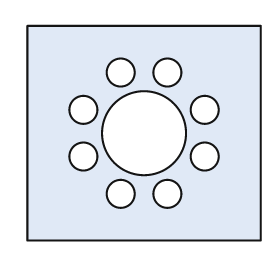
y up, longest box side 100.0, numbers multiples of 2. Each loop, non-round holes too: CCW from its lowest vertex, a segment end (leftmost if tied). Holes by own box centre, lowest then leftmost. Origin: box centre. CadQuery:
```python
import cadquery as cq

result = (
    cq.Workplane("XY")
    .moveTo(-50.0, -46.0)
    .lineTo(50.0, -46.0)
    .lineTo(50.0, 46.0)
    .lineTo(-50.0, 46.0)
    .close()
    .moveTo(-10.0, -26.0)
    .circle(6.0)
    .moveTo(10.0, -26.0)
    .circle(6.0)
    .moveTo(-26.0, -10.0)
    .circle(6.0)
    .moveTo(26.0, -10.0)
    .circle(6.0)
    .moveTo(0.0, 0.0)
    .circle(18.0)
    .moveTo(-26.0, 10.0)
    .circle(6.0)
    .moveTo(26.0, 10.0)
    .circle(6.0)
    .moveTo(-10.0, 26.0)
    .circle(6.0)
    .moveTo(10.0, 26.0)
    .circle(6.0)
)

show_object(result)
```